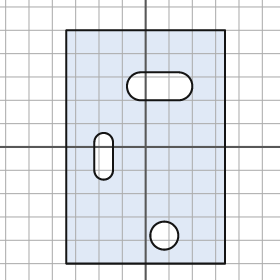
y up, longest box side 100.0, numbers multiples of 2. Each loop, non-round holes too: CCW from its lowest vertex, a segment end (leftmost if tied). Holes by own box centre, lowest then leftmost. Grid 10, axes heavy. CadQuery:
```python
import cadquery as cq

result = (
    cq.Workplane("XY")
    .moveTo(-34.0, -50.0)
    .lineTo(34.0, -50.0)
    .lineTo(34.0, 50.0)
    .lineTo(-34.0, 50.0)
    .close()
    .moveTo(8.0, -38.0)
    .circle(6.0)
    .moveTo(-22.0, -10.0)
    .threePointArc((-18.0, -14.0), (-14.0, -10.0))
    .lineTo(-14.0, 2.0)
    .threePointArc((-18.0, 6.0), (-22.0, 2.0))
    .close()
    .moveTo(-2.0, 20.0)
    .lineTo(14.0, 20.0)
    .threePointArc((20.0, 26.0), (14.0, 32.0))
    .lineTo(-2.0, 32.0)
    .threePointArc((-8.0, 26.0), (-2.0, 20.0))
    .close()
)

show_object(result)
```